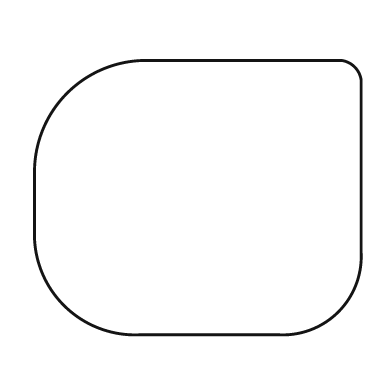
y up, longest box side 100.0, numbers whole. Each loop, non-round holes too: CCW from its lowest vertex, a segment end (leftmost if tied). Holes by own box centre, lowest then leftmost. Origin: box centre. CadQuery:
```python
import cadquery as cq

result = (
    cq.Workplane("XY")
    .moveTo(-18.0, -42.0)
    .lineTo(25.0, -42.0)
    .threePointArc((43.0, -35.0), (50.0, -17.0))
    .lineTo(50.0, 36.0)
    .threePointArc((48.0, 40.0), (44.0, 42.0))
    .lineTo(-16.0, 42.0)
    .threePointArc((-40.0, 32.0), (-50.0, 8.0))
    .lineTo(-50.0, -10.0)
    .threePointArc((-41.0, -33.0), (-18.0, -42.0))
    .close()
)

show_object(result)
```